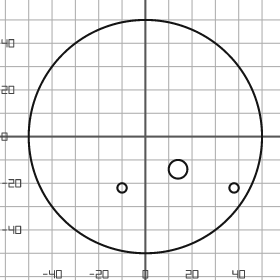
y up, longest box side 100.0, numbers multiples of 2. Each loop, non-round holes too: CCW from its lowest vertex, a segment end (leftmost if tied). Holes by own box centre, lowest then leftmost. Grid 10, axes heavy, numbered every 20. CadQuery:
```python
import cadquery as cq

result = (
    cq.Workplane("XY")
    .moveTo(0.0, 0.0)
    .circle(50.0)
    .moveTo(-10.0, -22.0)
    .circle(2.0)
    .moveTo(38.0, -22.0)
    .circle(2.0)
    .moveTo(14.0, -14.0)
    .circle(4.0)
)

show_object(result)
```